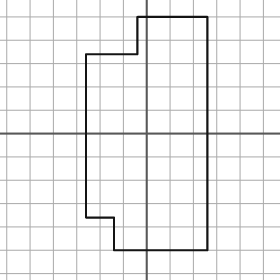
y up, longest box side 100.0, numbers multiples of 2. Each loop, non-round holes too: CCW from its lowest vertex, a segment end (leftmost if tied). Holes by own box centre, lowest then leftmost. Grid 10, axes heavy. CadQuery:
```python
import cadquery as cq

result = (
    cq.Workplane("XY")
    .moveTo(-14.0, -50.0)
    .lineTo(26.0, -50.0)
    .lineTo(26.0, 50.0)
    .lineTo(-4.0, 50.0)
    .lineTo(-4.0, 34.0)
    .lineTo(-26.0, 34.0)
    .lineTo(-26.0, -36.0)
    .lineTo(-14.0, -36.0)
    .close()
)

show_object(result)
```